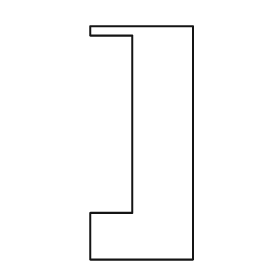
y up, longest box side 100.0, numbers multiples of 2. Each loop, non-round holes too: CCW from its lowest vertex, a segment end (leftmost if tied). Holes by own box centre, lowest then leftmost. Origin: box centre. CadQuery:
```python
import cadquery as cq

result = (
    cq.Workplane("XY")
    .moveTo(-22.0, -50.0)
    .lineTo(22.0, -50.0)
    .lineTo(22.0, 50.0)
    .lineTo(-22.0, 50.0)
    .lineTo(-22.0, 46.0)
    .lineTo(-4.0, 46.0)
    .lineTo(-4.0, -30.0)
    .lineTo(-22.0, -30.0)
    .close()
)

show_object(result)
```